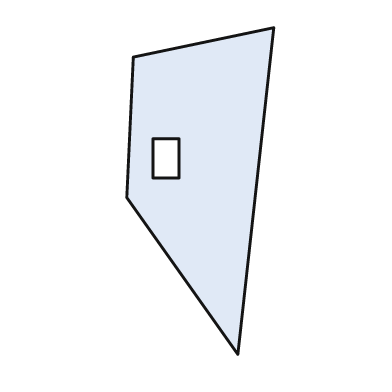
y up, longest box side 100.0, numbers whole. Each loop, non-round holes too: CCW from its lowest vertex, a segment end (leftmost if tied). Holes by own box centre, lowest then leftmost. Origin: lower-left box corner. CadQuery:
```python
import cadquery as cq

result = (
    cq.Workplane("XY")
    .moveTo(34.0, 0.0)
    .lineTo(45.0, 100.0)
    .lineTo(2.0, 91.0)
    .lineTo(0.0, 48.0)
    .close()
    .moveTo(8.0, 54.0)
    .lineTo(16.0, 54.0)
    .lineTo(16.0, 66.0)
    .lineTo(8.0, 66.0)
    .close()
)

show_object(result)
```